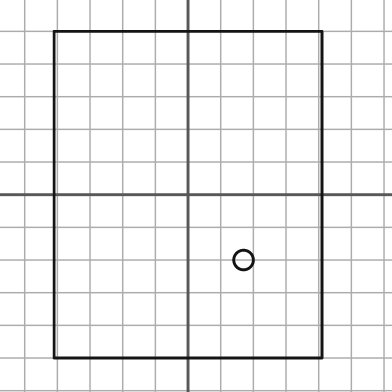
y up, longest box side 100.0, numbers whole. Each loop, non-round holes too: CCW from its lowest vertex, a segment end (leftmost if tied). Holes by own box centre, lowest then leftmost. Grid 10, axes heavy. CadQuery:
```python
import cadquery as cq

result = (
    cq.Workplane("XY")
    .moveTo(-41.0, -50.0)
    .lineTo(41.0, -50.0)
    .lineTo(41.0, 50.0)
    .lineTo(-41.0, 50.0)
    .close()
    .moveTo(17.0, -20.0)
    .circle(3.0)
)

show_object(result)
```